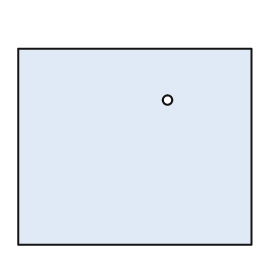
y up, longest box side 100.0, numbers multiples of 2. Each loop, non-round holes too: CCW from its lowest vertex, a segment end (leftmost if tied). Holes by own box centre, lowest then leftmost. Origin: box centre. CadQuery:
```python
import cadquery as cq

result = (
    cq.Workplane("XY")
    .moveTo(-50.0, -42.0)
    .lineTo(50.0, -42.0)
    .lineTo(50.0, 42.0)
    .lineTo(-50.0, 42.0)
    .close()
    .moveTo(14.0, 20.0)
    .circle(2.0)
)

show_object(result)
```